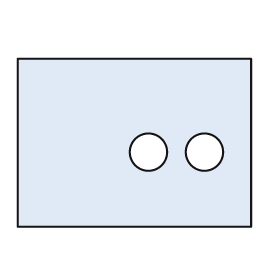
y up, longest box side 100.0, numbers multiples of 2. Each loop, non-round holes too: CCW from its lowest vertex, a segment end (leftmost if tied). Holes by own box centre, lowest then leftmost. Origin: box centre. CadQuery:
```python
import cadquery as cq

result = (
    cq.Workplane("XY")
    .moveTo(-50.0, -36.0)
    .lineTo(50.0, -36.0)
    .lineTo(50.0, 36.0)
    .lineTo(-50.0, 36.0)
    .close()
    .moveTo(6.0, -4.0)
    .circle(8.0)
    .moveTo(30.0, -4.0)
    .circle(8.0)
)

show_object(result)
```